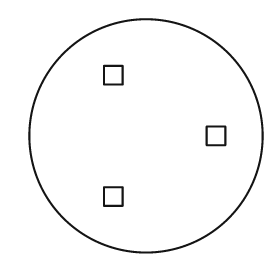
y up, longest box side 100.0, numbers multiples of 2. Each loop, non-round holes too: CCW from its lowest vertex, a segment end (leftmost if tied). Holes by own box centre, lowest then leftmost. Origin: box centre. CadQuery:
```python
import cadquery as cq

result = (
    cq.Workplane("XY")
    .moveTo(0.0, 0.0)
    .circle(50.0)
    .moveTo(-18.0, -30.0)
    .lineTo(-10.0, -30.0)
    .lineTo(-10.0, -22.0)
    .lineTo(-18.0, -22.0)
    .close()
    .moveTo(26.0, -4.0)
    .lineTo(34.0, -4.0)
    .lineTo(34.0, 4.0)
    .lineTo(26.0, 4.0)
    .close()
    .moveTo(-18.0, 22.0)
    .lineTo(-10.0, 22.0)
    .lineTo(-10.0, 30.0)
    .lineTo(-18.0, 30.0)
    .close()
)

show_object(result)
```